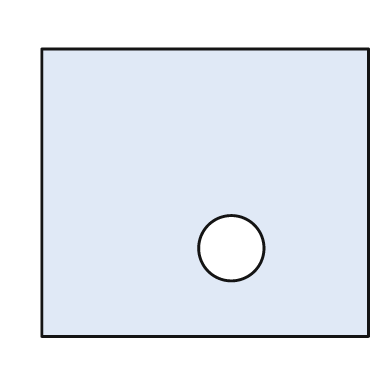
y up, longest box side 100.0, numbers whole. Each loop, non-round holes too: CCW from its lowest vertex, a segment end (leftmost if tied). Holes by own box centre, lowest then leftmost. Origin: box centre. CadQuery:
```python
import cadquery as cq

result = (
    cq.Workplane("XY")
    .moveTo(-50.0, -44.0)
    .lineTo(50.0, -44.0)
    .lineTo(50.0, 44.0)
    .lineTo(-50.0, 44.0)
    .close()
    .moveTo(8.0, -17.0)
    .circle(10.0)
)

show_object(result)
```